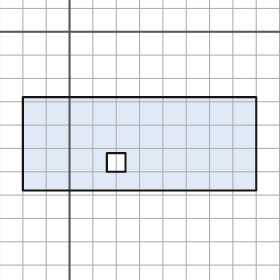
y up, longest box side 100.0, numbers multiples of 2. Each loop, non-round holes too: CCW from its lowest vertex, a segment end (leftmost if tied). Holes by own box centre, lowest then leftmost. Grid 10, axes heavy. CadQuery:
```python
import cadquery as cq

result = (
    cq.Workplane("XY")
    .moveTo(-20.0, -68.0)
    .lineTo(80.0, -68.0)
    .lineTo(80.0, -28.0)
    .lineTo(-20.0, -28.0)
    .close()
    .moveTo(16.0, -60.0)
    .lineTo(24.0, -60.0)
    .lineTo(24.0, -52.0)
    .lineTo(16.0, -52.0)
    .close()
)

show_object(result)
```